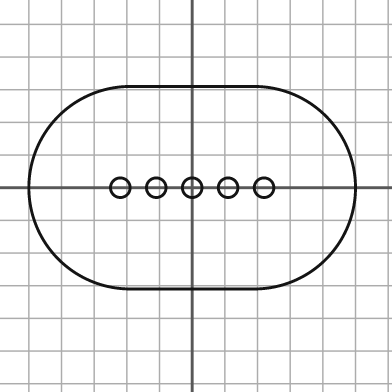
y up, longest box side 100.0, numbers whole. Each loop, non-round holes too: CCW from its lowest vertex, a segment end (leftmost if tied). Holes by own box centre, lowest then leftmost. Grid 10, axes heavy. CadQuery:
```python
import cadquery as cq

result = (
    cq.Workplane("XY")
    .moveTo(-19.0, -31.0)
    .lineTo(19.0, -31.0)
    .threePointArc((50.0, 0.0), (19.0, 31.0))
    .lineTo(-19.0, 31.0)
    .threePointArc((-50.0, 0.0), (-19.0, -31.0))
    .close()
    .moveTo(-22.0, 0.0)
    .circle(3.0)
    .moveTo(-11.0, 0.0)
    .circle(3.0)
    .moveTo(0.0, 0.0)
    .circle(3.0)
    .moveTo(11.0, 0.0)
    .circle(3.0)
    .moveTo(22.0, 0.0)
    .circle(3.0)
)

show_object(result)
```